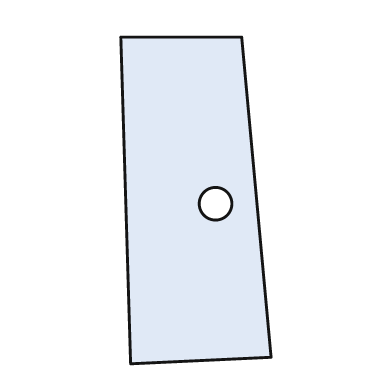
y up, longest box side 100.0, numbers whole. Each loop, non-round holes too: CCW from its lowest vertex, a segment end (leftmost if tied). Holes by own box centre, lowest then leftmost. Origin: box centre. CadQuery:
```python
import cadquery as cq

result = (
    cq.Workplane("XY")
    .moveTo(-20.0, -50.0)
    .lineTo(23.0, -48.0)
    .lineTo(14.0, 50.0)
    .lineTo(-23.0, 50.0)
    .close()
    .moveTo(6.0, -1.0)
    .circle(5.0)
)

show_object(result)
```